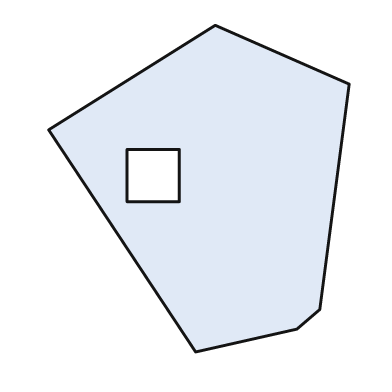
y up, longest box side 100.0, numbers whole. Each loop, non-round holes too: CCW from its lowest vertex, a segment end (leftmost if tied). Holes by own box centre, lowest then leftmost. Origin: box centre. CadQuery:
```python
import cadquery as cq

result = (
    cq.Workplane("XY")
    .moveTo(-1.0, -50.0)
    .lineTo(30.0, -43.0)
    .lineTo(37.0, -37.0)
    .lineTo(46.0, 32.0)
    .lineTo(5.0, 50.0)
    .lineTo(-46.0, 18.0)
    .close()
    .moveTo(-22.0, -4.0)
    .lineTo(-6.0, -4.0)
    .lineTo(-6.0, 12.0)
    .lineTo(-22.0, 12.0)
    .close()
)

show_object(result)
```